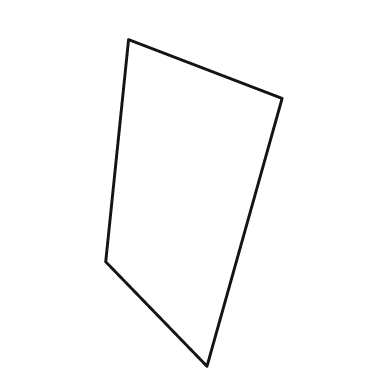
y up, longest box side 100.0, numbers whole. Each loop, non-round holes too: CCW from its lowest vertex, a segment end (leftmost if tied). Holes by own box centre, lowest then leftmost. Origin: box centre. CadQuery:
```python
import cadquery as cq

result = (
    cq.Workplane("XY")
    .moveTo(4.0, -50.0)
    .lineTo(27.0, 32.0)
    .lineTo(-20.0, 50.0)
    .lineTo(-27.0, -18.0)
    .close()
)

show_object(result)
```